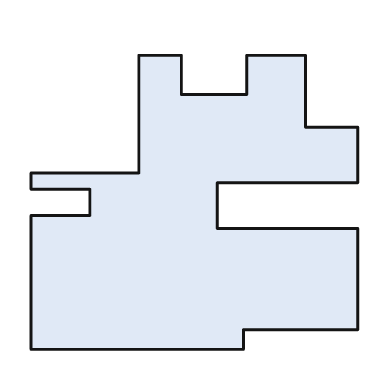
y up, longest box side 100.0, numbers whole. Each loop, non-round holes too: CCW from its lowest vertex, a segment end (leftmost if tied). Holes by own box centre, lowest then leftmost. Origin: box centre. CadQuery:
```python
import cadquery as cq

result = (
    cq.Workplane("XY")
    .moveTo(-50.0, -45.0)
    .lineTo(15.0, -45.0)
    .lineTo(15.0, -39.0)
    .lineTo(50.0, -39.0)
    .lineTo(50.0, -8.0)
    .lineTo(7.0, -8.0)
    .lineTo(7.0, 6.0)
    .lineTo(50.0, 6.0)
    .lineTo(50.0, 23.0)
    .lineTo(34.0, 23.0)
    .lineTo(34.0, 45.0)
    .lineTo(16.0, 45.0)
    .lineTo(16.0, 33.0)
    .lineTo(-4.0, 33.0)
    .lineTo(-4.0, 45.0)
    .lineTo(-17.0, 45.0)
    .lineTo(-17.0, 9.0)
    .lineTo(-50.0, 9.0)
    .lineTo(-50.0, 4.0)
    .lineTo(-32.0, 4.0)
    .lineTo(-32.0, -4.0)
    .lineTo(-50.0, -4.0)
    .close()
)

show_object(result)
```